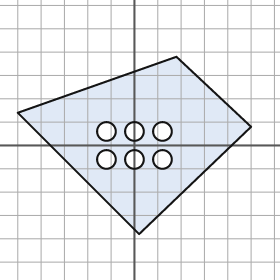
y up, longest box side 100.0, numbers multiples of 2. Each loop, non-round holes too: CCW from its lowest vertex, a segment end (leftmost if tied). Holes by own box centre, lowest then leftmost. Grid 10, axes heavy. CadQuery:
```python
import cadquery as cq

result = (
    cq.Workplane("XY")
    .moveTo(2.0, -38.0)
    .lineTo(50.0, 8.0)
    .lineTo(18.0, 38.0)
    .lineTo(-50.0, 14.0)
    .close()
    .moveTo(-12.0, -6.0)
    .circle(4.0)
    .moveTo(0.0, -6.0)
    .circle(4.0)
    .moveTo(12.0, -6.0)
    .circle(4.0)
    .moveTo(-12.0, 6.0)
    .circle(4.0)
    .moveTo(0.0, 6.0)
    .circle(4.0)
    .moveTo(12.0, 6.0)
    .circle(4.0)
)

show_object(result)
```